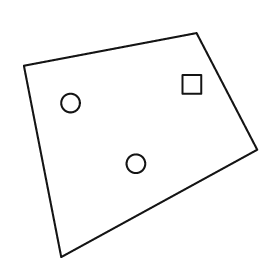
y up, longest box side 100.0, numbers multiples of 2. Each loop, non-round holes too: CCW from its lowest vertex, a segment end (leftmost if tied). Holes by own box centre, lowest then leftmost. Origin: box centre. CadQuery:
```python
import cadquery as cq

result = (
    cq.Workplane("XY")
    .moveTo(-34.0, -48.0)
    .lineTo(50.0, -2.0)
    .lineTo(24.0, 48.0)
    .lineTo(-50.0, 34.0)
    .close()
    .moveTo(-2.0, -8.0)
    .circle(4.0)
    .moveTo(-30.0, 18.0)
    .circle(4.0)
    .moveTo(18.0, 22.0)
    .lineTo(26.0, 22.0)
    .lineTo(26.0, 30.0)
    .lineTo(18.0, 30.0)
    .close()
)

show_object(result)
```